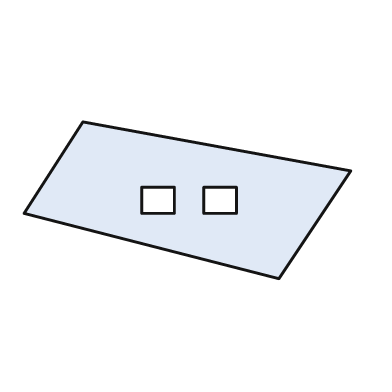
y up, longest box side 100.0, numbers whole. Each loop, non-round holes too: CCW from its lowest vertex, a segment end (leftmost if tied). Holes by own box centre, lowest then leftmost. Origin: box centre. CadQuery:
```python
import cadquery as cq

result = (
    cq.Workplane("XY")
    .moveTo(28.0, -24.0)
    .lineTo(50.0, 9.0)
    .lineTo(-32.0, 24.0)
    .lineTo(-50.0, -4.0)
    .close()
    .moveTo(-14.0, -4.0)
    .lineTo(-4.0, -4.0)
    .lineTo(-4.0, 4.0)
    .lineTo(-14.0, 4.0)
    .close()
    .moveTo(5.0, -4.0)
    .lineTo(15.0, -4.0)
    .lineTo(15.0, 4.0)
    .lineTo(5.0, 4.0)
    .close()
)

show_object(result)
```